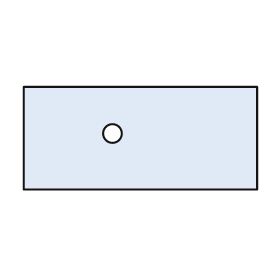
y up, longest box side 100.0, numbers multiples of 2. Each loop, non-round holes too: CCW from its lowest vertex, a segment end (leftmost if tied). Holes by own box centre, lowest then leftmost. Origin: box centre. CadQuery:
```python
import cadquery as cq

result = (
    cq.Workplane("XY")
    .moveTo(-50.0, -22.0)
    .lineTo(50.0, -22.0)
    .lineTo(50.0, 22.0)
    .lineTo(-50.0, 22.0)
    .close()
    .moveTo(-12.0, 2.0)
    .circle(4.0)
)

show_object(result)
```